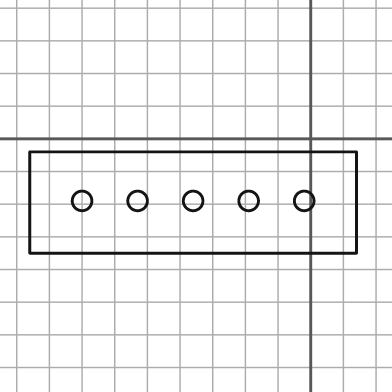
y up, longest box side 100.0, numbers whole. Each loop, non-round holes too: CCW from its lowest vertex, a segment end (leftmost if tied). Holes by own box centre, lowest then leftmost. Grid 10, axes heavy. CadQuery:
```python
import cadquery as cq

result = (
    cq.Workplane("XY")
    .moveTo(-86.0, -35.0)
    .lineTo(14.0, -35.0)
    .lineTo(14.0, -4.0)
    .lineTo(-86.0, -4.0)
    .close()
    .moveTo(-70.0, -19.0)
    .circle(3.0)
    .moveTo(-53.0, -19.0)
    .circle(3.0)
    .moveTo(-36.0, -19.0)
    .circle(3.0)
    .moveTo(-19.0, -19.0)
    .circle(3.0)
    .moveTo(-2.0, -19.0)
    .circle(3.0)
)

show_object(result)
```